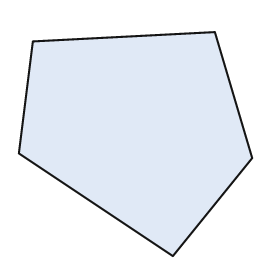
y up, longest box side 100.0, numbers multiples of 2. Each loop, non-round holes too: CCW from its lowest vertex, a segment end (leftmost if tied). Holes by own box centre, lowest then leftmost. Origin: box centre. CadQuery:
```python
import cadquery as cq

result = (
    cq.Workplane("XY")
    .moveTo(16.0, -48.0)
    .lineTo(50.0, -6.0)
    .lineTo(34.0, 48.0)
    .lineTo(-44.0, 44.0)
    .lineTo(-50.0, -4.0)
    .close()
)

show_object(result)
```